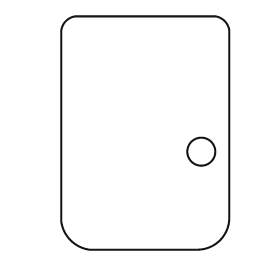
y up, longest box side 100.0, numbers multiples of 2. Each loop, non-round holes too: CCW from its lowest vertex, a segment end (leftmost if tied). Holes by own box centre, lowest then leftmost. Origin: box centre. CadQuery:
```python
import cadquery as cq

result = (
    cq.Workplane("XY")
    .moveTo(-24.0, -50.0)
    .lineTo(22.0, -50.0)
    .threePointArc((32.0, -46.0), (36.0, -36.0))
    .lineTo(36.0, 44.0)
    .threePointArc((34.0, 48.0), (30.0, 50.0))
    .lineTo(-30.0, 50.0)
    .threePointArc((-34.0, 48.0), (-36.0, 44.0))
    .lineTo(-36.0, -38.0)
    .threePointArc((-32.0, -46.0), (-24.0, -50.0))
    .close()
    .moveTo(24.0, -8.0)
    .circle(6.0)
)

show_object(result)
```